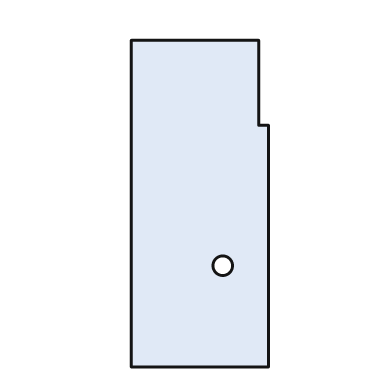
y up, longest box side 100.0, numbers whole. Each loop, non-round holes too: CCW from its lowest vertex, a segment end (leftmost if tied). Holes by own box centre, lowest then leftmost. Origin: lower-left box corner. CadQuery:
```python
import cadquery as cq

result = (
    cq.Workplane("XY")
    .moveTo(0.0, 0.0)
    .lineTo(42.0, 0.0)
    .lineTo(42.0, 74.0)
    .lineTo(39.0, 74.0)
    .lineTo(39.0, 100.0)
    .lineTo(0.0, 100.0)
    .close()
    .moveTo(28.0, 31.0)
    .circle(3.0)
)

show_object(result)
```